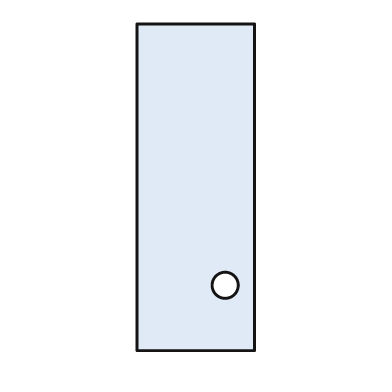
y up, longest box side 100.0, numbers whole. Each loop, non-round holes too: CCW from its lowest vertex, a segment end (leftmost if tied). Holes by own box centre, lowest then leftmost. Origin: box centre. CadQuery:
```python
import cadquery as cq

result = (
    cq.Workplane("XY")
    .moveTo(-18.0, -50.0)
    .lineTo(18.0, -50.0)
    .lineTo(18.0, 50.0)
    .lineTo(-18.0, 50.0)
    .close()
    .moveTo(9.0, -30.0)
    .circle(4.0)
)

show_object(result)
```